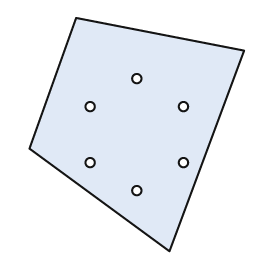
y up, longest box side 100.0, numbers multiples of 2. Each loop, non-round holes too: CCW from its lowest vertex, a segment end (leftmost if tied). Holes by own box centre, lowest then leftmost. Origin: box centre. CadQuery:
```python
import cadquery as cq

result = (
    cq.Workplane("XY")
    .moveTo(14.0, -50.0)
    .lineTo(46.0, 36.0)
    .lineTo(-26.0, 50.0)
    .lineTo(-46.0, -6.0)
    .close()
    .moveTo(0.0, -24.0)
    .circle(2.0)
    .moveTo(-20.0, -12.0)
    .circle(2.0)
    .moveTo(20.0, -12.0)
    .circle(2.0)
    .moveTo(-20.0, 12.0)
    .circle(2.0)
    .moveTo(20.0, 12.0)
    .circle(2.0)
    .moveTo(0.0, 24.0)
    .circle(2.0)
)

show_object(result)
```